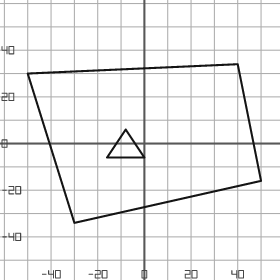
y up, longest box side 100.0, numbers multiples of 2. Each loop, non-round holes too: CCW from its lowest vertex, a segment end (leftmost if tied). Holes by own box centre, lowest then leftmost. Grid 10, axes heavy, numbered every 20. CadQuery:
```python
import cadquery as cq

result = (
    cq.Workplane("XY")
    .moveTo(-30.0, -34.0)
    .lineTo(50.0, -16.0)
    .lineTo(40.0, 34.0)
    .lineTo(-50.0, 30.0)
    .close()
    .moveTo(-16.0, -6.0)
    .lineTo(0.0, -6.0)
    .lineTo(-8.0, 6.0)
    .close()
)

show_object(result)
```